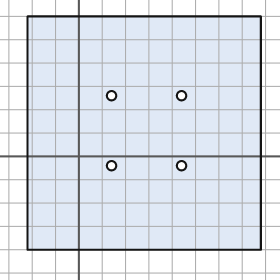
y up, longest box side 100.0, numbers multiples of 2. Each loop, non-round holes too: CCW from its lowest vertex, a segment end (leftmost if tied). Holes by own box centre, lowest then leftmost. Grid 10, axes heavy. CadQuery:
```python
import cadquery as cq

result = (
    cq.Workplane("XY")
    .moveTo(-22.0, -40.0)
    .lineTo(78.0, -40.0)
    .lineTo(78.0, 60.0)
    .lineTo(-22.0, 60.0)
    .close()
    .moveTo(14.0, -4.0)
    .circle(2.0)
    .moveTo(44.0, -4.0)
    .circle(2.0)
    .moveTo(14.0, 26.0)
    .circle(2.0)
    .moveTo(44.0, 26.0)
    .circle(2.0)
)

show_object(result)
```